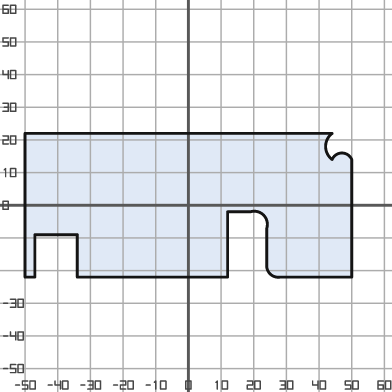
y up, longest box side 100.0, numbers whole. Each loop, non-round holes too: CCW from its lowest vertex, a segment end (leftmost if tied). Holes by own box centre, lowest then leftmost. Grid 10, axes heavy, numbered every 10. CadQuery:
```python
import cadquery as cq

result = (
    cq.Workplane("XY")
    .moveTo(-50.0, -22.0)
    .lineTo(-47.0, -22.0)
    .lineTo(-47.0, -9.0)
    .lineTo(-34.0, -9.0)
    .lineTo(-34.0, -22.0)
    .lineTo(12.0, -22.0)
    .lineTo(12.0, -2.0)
    .lineTo(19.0, -2.0)
    .threePointArc((23.0, -3.0), (24.0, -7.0))
    .lineTo(24.0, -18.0)
    .threePointArc((25.0, -21.0), (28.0, -22.0))
    .lineTo(50.0, -22.0)
    .lineTo(50.0, 14.0)
    .threePointArc((47.0, 16.0), (44.0, 14.0))
    .threePointArc((42.0, 18.0), (44.0, 22.0))
    .lineTo(-50.0, 22.0)
    .close()
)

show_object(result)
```